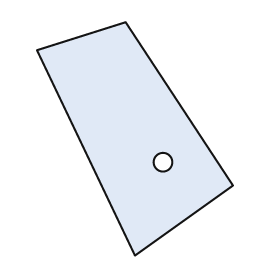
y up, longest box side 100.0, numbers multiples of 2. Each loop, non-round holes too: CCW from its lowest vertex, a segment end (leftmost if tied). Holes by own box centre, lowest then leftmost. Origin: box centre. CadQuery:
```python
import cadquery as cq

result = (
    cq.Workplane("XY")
    .moveTo(0.0, -50.0)
    .lineTo(42.0, -20.0)
    .lineTo(-4.0, 50.0)
    .lineTo(-42.0, 38.0)
    .close()
    .moveTo(12.0, -10.0)
    .circle(4.0)
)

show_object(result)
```